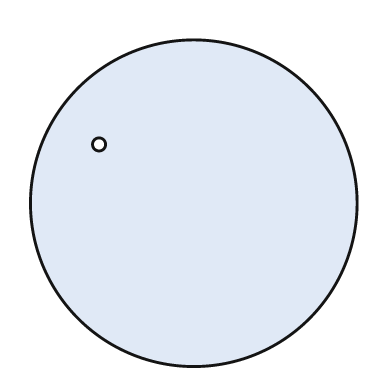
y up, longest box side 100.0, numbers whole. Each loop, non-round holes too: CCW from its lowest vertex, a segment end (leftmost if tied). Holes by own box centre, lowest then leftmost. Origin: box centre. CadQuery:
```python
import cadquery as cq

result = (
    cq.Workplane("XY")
    .moveTo(0.0, 0.0)
    .circle(50.0)
    .moveTo(-29.0, 18.0)
    .circle(2.0)
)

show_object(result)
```